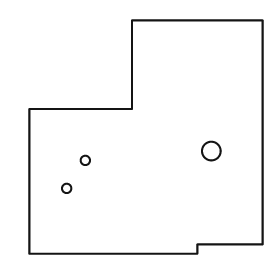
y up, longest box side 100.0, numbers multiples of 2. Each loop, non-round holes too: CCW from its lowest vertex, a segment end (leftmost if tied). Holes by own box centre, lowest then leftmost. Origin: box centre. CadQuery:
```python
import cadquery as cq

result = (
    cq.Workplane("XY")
    .moveTo(-50.0, -50.0)
    .lineTo(22.0, -50.0)
    .lineTo(22.0, -46.0)
    .lineTo(50.0, -46.0)
    .lineTo(50.0, 50.0)
    .lineTo(-6.0, 50.0)
    .lineTo(-6.0, 12.0)
    .lineTo(-50.0, 12.0)
    .close()
    .moveTo(-34.0, -22.0)
    .circle(2.0)
    .moveTo(-26.0, -10.0)
    .circle(2.0)
    .moveTo(28.0, -6.0)
    .circle(4.0)
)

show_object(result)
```